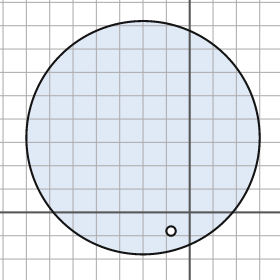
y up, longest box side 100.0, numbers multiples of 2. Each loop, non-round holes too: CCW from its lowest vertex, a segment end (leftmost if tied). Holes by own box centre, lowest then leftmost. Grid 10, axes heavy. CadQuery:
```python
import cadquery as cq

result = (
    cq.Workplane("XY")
    .moveTo(-20.0, 32.0)
    .circle(50.0)
    .moveTo(-8.0, -8.0)
    .circle(2.0)
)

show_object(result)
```